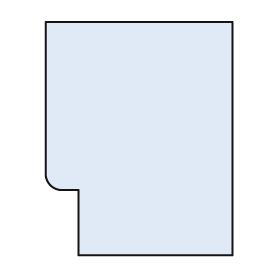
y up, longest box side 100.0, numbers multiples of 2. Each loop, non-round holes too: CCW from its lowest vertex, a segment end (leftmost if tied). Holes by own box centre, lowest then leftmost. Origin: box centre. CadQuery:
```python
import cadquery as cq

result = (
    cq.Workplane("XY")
    .moveTo(-26.0, -50.0)
    .lineTo(40.0, -50.0)
    .lineTo(40.0, 50.0)
    .lineTo(-40.0, 50.0)
    .lineTo(-40.0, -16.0)
    .threePointArc((-38.0, -20.0), (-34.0, -22.0))
    .lineTo(-26.0, -22.0)
    .close()
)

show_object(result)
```